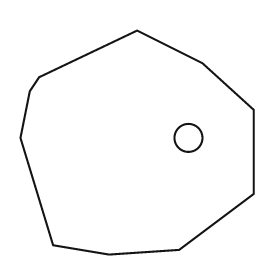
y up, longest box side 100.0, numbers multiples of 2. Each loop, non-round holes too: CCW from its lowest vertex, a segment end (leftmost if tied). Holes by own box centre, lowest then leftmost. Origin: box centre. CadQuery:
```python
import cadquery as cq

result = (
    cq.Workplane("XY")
    .moveTo(-12.0, -48.0)
    .lineTo(18.0, -46.0)
    .lineTo(50.0, -22.0)
    .lineTo(50.0, 14.0)
    .lineTo(28.0, 34.0)
    .lineTo(0.0, 48.0)
    .lineTo(-42.0, 28.0)
    .lineTo(-46.0, 22.0)
    .lineTo(-50.0, 2.0)
    .lineTo(-36.0, -44.0)
    .close()
    .moveTo(22.0, 2.0)
    .circle(6.0)
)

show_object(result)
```